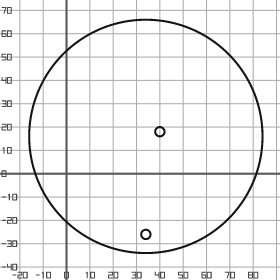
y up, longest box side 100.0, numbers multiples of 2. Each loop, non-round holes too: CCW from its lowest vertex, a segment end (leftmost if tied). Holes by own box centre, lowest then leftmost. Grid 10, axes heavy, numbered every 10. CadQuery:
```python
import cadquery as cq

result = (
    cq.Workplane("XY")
    .moveTo(34.0, 16.0)
    .circle(50.0)
    .moveTo(34.0, -26.0)
    .circle(2.0)
    .moveTo(40.0, 18.0)
    .circle(2.0)
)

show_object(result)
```